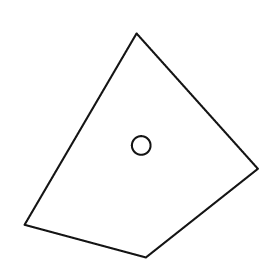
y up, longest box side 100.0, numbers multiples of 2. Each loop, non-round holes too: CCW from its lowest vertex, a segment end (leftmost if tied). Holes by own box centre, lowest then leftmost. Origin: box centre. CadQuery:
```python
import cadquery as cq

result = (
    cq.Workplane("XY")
    .moveTo(2.0, -48.0)
    .lineTo(50.0, -10.0)
    .lineTo(-2.0, 48.0)
    .lineTo(-50.0, -34.0)
    .close()
    .moveTo(0.0, 0.0)
    .circle(4.0)
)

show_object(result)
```